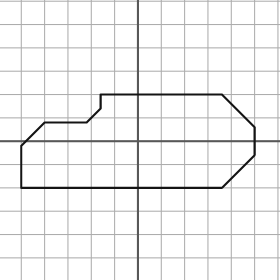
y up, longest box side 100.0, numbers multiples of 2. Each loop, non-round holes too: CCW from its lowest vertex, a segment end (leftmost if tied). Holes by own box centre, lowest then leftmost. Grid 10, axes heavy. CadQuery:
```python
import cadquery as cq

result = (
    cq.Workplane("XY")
    .moveTo(-50.0, -20.0)
    .lineTo(36.0, -20.0)
    .lineTo(50.0, -6.0)
    .lineTo(50.0, 6.0)
    .lineTo(36.0, 20.0)
    .lineTo(-16.0, 20.0)
    .lineTo(-16.0, 14.0)
    .lineTo(-22.0, 8.0)
    .lineTo(-40.0, 8.0)
    .lineTo(-50.0, -2.0)
    .close()
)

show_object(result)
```